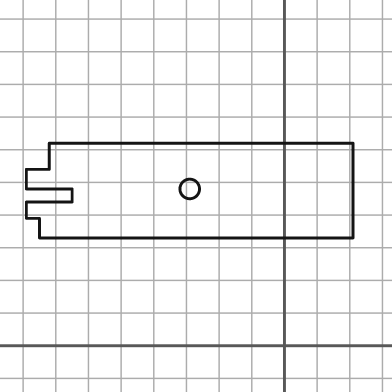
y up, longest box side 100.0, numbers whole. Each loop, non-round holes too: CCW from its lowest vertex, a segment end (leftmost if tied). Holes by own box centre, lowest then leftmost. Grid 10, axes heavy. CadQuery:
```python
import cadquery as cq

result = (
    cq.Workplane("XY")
    .moveTo(-75.0, 33.0)
    .lineTo(21.0, 33.0)
    .lineTo(21.0, 62.0)
    .lineTo(-72.0, 62.0)
    .lineTo(-72.0, 54.0)
    .lineTo(-79.0, 54.0)
    .lineTo(-79.0, 48.0)
    .lineTo(-65.0, 48.0)
    .lineTo(-65.0, 44.0)
    .lineTo(-79.0, 44.0)
    .lineTo(-79.0, 39.0)
    .lineTo(-75.0, 39.0)
    .close()
    .moveTo(-29.0, 48.0)
    .circle(3.0)
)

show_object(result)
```